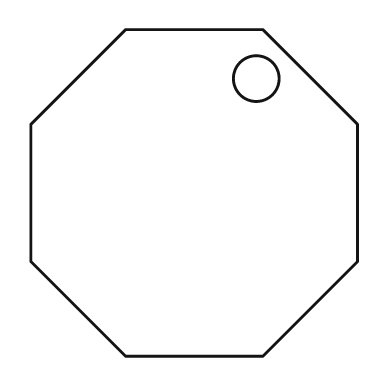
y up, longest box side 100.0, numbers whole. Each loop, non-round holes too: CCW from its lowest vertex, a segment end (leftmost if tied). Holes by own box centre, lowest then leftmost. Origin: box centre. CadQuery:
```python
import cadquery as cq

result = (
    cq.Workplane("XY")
    .moveTo(-21.0, -50.0)
    .lineTo(21.0, -50.0)
    .lineTo(50.0, -21.0)
    .lineTo(50.0, 21.0)
    .lineTo(21.0, 50.0)
    .lineTo(-21.0, 50.0)
    .lineTo(-50.0, 21.0)
    .lineTo(-50.0, -21.0)
    .close()
    .moveTo(19.0, 35.0)
    .circle(7.0)
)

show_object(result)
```